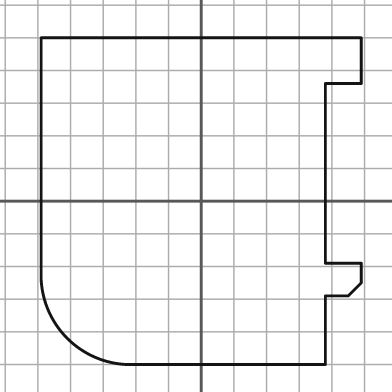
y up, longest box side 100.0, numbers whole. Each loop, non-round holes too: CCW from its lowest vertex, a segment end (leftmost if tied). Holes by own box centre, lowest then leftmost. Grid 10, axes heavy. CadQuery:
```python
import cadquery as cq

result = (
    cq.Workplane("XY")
    .moveTo(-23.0, -50.0)
    .lineTo(38.0, -50.0)
    .lineTo(38.0, -29.0)
    .lineTo(45.0, -29.0)
    .lineTo(49.0, -25.0)
    .lineTo(49.0, -19.0)
    .lineTo(38.0, -19.0)
    .lineTo(38.0, 36.0)
    .lineTo(49.0, 36.0)
    .lineTo(49.0, 50.0)
    .lineTo(-49.0, 50.0)
    .lineTo(-49.0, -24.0)
    .threePointArc((-41.0, -42.0), (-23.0, -50.0))
    .close()
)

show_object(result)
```